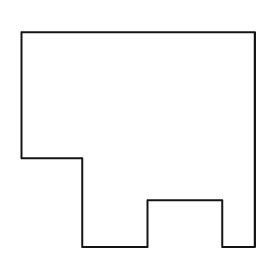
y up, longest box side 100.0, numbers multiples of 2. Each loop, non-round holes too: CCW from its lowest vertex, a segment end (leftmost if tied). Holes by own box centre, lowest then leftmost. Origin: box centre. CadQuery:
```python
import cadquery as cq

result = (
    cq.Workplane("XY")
    .moveTo(-24.0, -46.0)
    .lineTo(4.0, -46.0)
    .lineTo(4.0, -26.0)
    .lineTo(36.0, -26.0)
    .lineTo(36.0, -46.0)
    .lineTo(50.0, -46.0)
    .lineTo(50.0, 46.0)
    .lineTo(-50.0, 46.0)
    .lineTo(-50.0, -8.0)
    .lineTo(-24.0, -8.0)
    .close()
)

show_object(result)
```